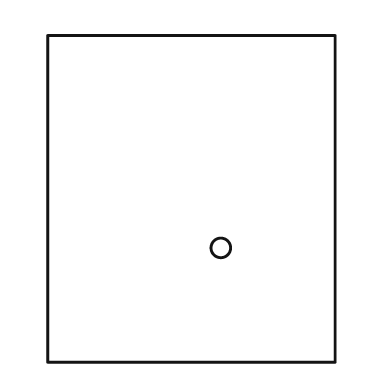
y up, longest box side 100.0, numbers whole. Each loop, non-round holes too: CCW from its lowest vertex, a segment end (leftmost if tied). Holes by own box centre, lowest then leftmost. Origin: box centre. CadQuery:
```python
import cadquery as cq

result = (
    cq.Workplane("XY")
    .moveTo(-44.0, -50.0)
    .lineTo(44.0, -50.0)
    .lineTo(44.0, 50.0)
    .lineTo(-44.0, 50.0)
    .close()
    .moveTo(9.0, -15.0)
    .circle(3.0)
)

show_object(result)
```